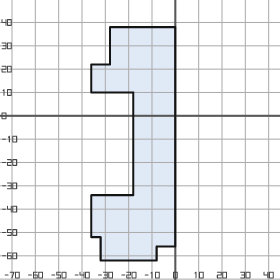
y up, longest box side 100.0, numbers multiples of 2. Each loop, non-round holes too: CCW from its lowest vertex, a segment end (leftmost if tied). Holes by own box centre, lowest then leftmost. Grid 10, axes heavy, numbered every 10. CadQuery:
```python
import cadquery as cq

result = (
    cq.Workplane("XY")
    .moveTo(-32.0, -62.0)
    .lineTo(-8.0, -62.0)
    .lineTo(-8.0, -56.0)
    .lineTo(0.0, -56.0)
    .lineTo(0.0, 38.0)
    .lineTo(-28.0, 38.0)
    .lineTo(-28.0, 22.0)
    .lineTo(-36.0, 22.0)
    .lineTo(-36.0, 10.0)
    .lineTo(-18.0, 10.0)
    .lineTo(-18.0, -34.0)
    .lineTo(-36.0, -34.0)
    .lineTo(-36.0, -52.0)
    .lineTo(-32.0, -52.0)
    .close()
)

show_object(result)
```